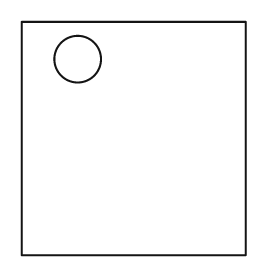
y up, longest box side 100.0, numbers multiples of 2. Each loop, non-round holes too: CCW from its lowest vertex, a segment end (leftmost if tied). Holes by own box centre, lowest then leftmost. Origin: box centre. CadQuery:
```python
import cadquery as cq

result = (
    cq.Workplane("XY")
    .moveTo(-48.0, -50.0)
    .lineTo(48.0, -50.0)
    .lineTo(48.0, 50.0)
    .lineTo(-48.0, 50.0)
    .close()
    .moveTo(-24.0, 34.0)
    .circle(10.0)
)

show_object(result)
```